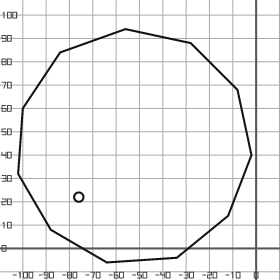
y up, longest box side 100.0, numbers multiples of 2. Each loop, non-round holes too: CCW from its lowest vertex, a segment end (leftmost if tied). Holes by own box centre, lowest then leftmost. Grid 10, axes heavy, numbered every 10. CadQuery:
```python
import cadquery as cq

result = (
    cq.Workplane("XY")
    .moveTo(-64.0, -6.0)
    .lineTo(-34.0, -4.0)
    .lineTo(-12.0, 14.0)
    .lineTo(-2.0, 40.0)
    .lineTo(-8.0, 68.0)
    .lineTo(-28.0, 88.0)
    .lineTo(-56.0, 94.0)
    .lineTo(-84.0, 84.0)
    .lineTo(-100.0, 60.0)
    .lineTo(-102.0, 32.0)
    .lineTo(-88.0, 8.0)
    .close()
    .moveTo(-76.0, 22.0)
    .circle(2.0)
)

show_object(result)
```